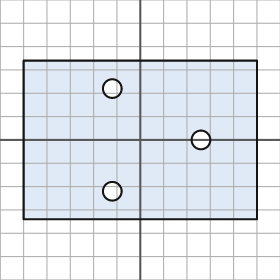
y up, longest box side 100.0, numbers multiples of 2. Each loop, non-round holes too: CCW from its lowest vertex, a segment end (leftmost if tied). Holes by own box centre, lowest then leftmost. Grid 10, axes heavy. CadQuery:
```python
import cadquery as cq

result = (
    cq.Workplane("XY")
    .moveTo(-50.0, -34.0)
    .lineTo(50.0, -34.0)
    .lineTo(50.0, 34.0)
    .lineTo(-50.0, 34.0)
    .close()
    .moveTo(-12.0, -22.0)
    .circle(4.0)
    .moveTo(26.0, 0.0)
    .circle(4.0)
    .moveTo(-12.0, 22.0)
    .circle(4.0)
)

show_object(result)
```